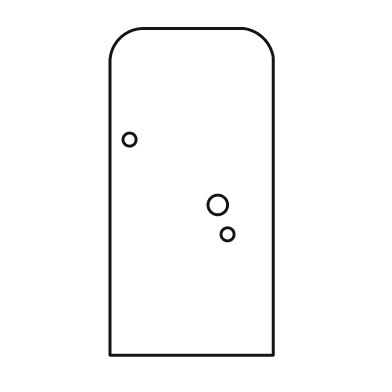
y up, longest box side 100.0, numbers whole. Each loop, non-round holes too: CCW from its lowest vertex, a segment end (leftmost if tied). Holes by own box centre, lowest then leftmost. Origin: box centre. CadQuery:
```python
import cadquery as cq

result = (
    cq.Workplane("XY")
    .moveTo(-25.0, -50.0)
    .lineTo(25.0, -50.0)
    .lineTo(25.0, 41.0)
    .threePointArc((22.0, 47.0), (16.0, 50.0))
    .lineTo(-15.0, 50.0)
    .threePointArc((-22.0, 47.0), (-25.0, 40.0))
    .close()
    .moveTo(11.0, -13.0)
    .circle(2.0)
    .moveTo(8.0, -4.0)
    .circle(3.0)
    .moveTo(-19.0, 16.0)
    .circle(2.0)
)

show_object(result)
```